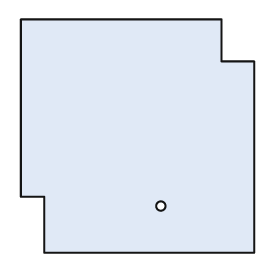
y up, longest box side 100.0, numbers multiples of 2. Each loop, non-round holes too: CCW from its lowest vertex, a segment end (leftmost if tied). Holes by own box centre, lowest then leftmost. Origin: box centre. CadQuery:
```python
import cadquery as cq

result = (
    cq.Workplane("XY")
    .moveTo(-40.0, -50.0)
    .lineTo(50.0, -50.0)
    .lineTo(50.0, 32.0)
    .lineTo(36.0, 32.0)
    .lineTo(36.0, 50.0)
    .lineTo(-50.0, 50.0)
    .lineTo(-50.0, -26.0)
    .lineTo(-40.0, -26.0)
    .close()
    .moveTo(10.0, -30.0)
    .circle(2.0)
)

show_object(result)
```